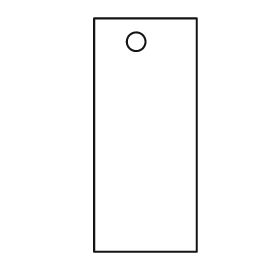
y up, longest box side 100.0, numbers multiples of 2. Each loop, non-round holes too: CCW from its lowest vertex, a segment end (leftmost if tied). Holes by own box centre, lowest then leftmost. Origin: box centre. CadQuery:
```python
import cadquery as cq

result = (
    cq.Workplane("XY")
    .moveTo(-22.0, -50.0)
    .lineTo(22.0, -50.0)
    .lineTo(22.0, 50.0)
    .lineTo(-22.0, 50.0)
    .close()
    .moveTo(-4.0, 40.0)
    .circle(4.0)
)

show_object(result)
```